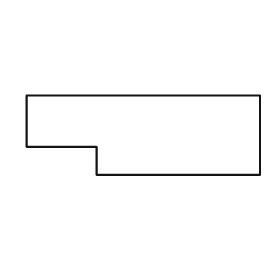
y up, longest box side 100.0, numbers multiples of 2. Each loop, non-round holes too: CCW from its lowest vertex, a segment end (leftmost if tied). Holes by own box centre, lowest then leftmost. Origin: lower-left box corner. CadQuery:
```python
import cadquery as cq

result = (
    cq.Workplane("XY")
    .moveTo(30.0, 0.0)
    .lineTo(100.0, 0.0)
    .lineTo(100.0, 34.0)
    .lineTo(0.0, 34.0)
    .lineTo(0.0, 12.0)
    .lineTo(30.0, 12.0)
    .close()
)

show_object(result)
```